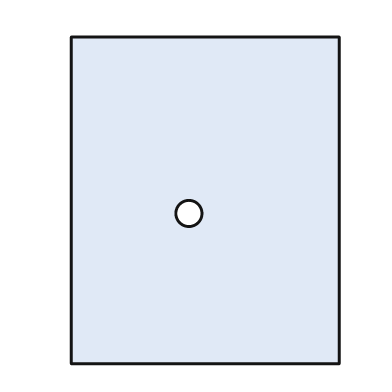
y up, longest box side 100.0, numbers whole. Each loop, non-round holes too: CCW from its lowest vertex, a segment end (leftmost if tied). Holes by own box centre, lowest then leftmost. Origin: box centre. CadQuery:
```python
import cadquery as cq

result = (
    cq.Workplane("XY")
    .moveTo(-41.0, -50.0)
    .lineTo(41.0, -50.0)
    .lineTo(41.0, 50.0)
    .lineTo(-41.0, 50.0)
    .close()
    .moveTo(-5.0, -4.0)
    .circle(4.0)
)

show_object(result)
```